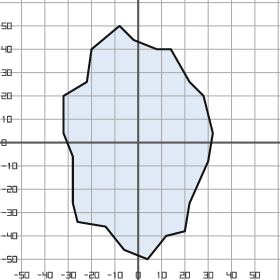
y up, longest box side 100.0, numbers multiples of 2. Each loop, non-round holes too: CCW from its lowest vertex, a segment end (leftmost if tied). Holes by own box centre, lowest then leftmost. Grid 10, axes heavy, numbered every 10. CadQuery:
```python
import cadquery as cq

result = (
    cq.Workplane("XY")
    .moveTo(4.0, -50.0)
    .lineTo(12.0, -40.0)
    .lineTo(20.0, -38.0)
    .lineTo(22.0, -26.0)
    .lineTo(30.0, -8.0)
    .lineTo(32.0, 4.0)
    .lineTo(28.0, 20.0)
    .lineTo(22.0, 26.0)
    .lineTo(14.0, 40.0)
    .lineTo(8.0, 40.0)
    .lineTo(-2.0, 44.0)
    .lineTo(-8.0, 50.0)
    .lineTo(-20.0, 40.0)
    .lineTo(-22.0, 26.0)
    .lineTo(-32.0, 20.0)
    .lineTo(-32.0, 4.0)
    .lineTo(-28.0, -6.0)
    .lineTo(-28.0, -26.0)
    .lineTo(-26.0, -34.0)
    .lineTo(-14.0, -36.0)
    .lineTo(-6.0, -46.0)
    .close()
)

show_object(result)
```